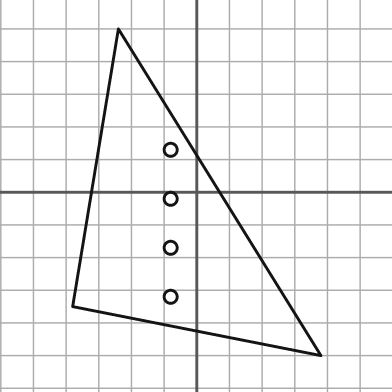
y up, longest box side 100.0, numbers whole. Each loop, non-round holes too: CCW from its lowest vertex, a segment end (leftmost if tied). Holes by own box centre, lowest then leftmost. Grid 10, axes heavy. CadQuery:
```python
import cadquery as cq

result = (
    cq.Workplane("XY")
    .moveTo(38.0, -50.0)
    .lineTo(-24.0, 50.0)
    .lineTo(-38.0, -35.0)
    .close()
    .moveTo(-8.0, -32.0)
    .circle(2.0)
    .moveTo(-8.0, -17.0)
    .circle(2.0)
    .moveTo(-8.0, -2.0)
    .circle(2.0)
    .moveTo(-8.0, 13.0)
    .circle(2.0)
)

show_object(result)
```